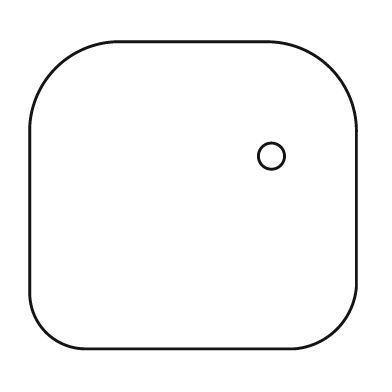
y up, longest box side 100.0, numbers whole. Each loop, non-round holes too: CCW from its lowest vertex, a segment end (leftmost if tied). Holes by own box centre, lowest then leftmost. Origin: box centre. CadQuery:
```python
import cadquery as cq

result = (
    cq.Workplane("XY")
    .moveTo(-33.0, -47.0)
    .lineTo(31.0, -47.0)
    .threePointArc((44.0, -41.0), (50.0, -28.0))
    .lineTo(50.0, 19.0)
    .threePointArc((42.0, 39.0), (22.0, 47.0))
    .lineTo(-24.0, 47.0)
    .threePointArc((-42.0, 39.0), (-50.0, 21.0))
    .lineTo(-50.0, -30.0)
    .threePointArc((-45.0, -42.0), (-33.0, -47.0))
    .close()
    .moveTo(24.0, 12.0)
    .circle(4.0)
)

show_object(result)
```